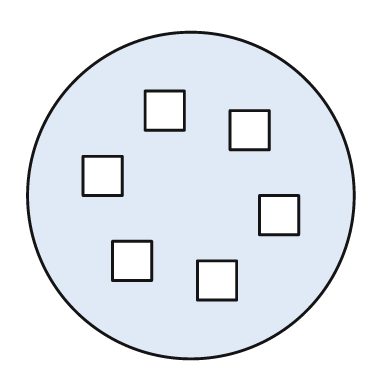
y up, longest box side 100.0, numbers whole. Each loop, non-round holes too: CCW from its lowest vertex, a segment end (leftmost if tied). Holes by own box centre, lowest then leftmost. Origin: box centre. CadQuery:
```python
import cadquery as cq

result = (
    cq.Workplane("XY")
    .moveTo(0.0, 0.0)
    .circle(50.0)
    .moveTo(2.0, -32.0)
    .lineTo(14.0, -32.0)
    .lineTo(14.0, -20.0)
    .lineTo(2.0, -20.0)
    .close()
    .moveTo(-24.0, -26.0)
    .lineTo(-12.0, -26.0)
    .lineTo(-12.0, -14.0)
    .lineTo(-24.0, -14.0)
    .close()
    .moveTo(21.0, -12.0)
    .lineTo(33.0, -12.0)
    .lineTo(33.0, 0.0)
    .lineTo(21.0, 0.0)
    .close()
    .moveTo(-33.0, 0.0)
    .lineTo(-21.0, 0.0)
    .lineTo(-21.0, 12.0)
    .lineTo(-33.0, 12.0)
    .close()
    .moveTo(12.0, 14.0)
    .lineTo(24.0, 14.0)
    .lineTo(24.0, 26.0)
    .lineTo(12.0, 26.0)
    .close()
    .moveTo(-14.0, 20.0)
    .lineTo(-2.0, 20.0)
    .lineTo(-2.0, 32.0)
    .lineTo(-14.0, 32.0)
    .close()
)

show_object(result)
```